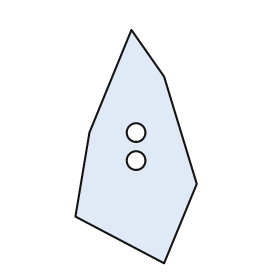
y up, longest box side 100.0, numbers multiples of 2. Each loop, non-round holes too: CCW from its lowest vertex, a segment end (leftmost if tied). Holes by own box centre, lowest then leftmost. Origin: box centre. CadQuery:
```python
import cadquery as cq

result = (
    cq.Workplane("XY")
    .moveTo(12.0, -50.0)
    .lineTo(26.0, -16.0)
    .lineTo(12.0, 30.0)
    .lineTo(-2.0, 50.0)
    .lineTo(-20.0, 6.0)
    .lineTo(-26.0, -30.0)
    .close()
    .moveTo(0.0, -6.0)
    .circle(4.0)
    .moveTo(0.0, 6.0)
    .circle(4.0)
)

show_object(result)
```